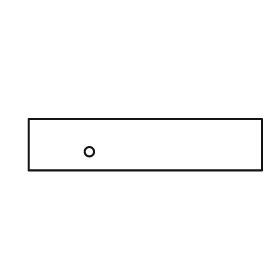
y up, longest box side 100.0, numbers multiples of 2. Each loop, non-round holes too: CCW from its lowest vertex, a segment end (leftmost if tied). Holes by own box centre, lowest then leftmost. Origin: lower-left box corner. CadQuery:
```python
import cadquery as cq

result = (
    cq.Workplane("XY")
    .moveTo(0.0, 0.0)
    .lineTo(100.0, 0.0)
    .lineTo(100.0, 22.0)
    .lineTo(0.0, 22.0)
    .close()
    .moveTo(26.0, 8.0)
    .circle(2.0)
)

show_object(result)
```